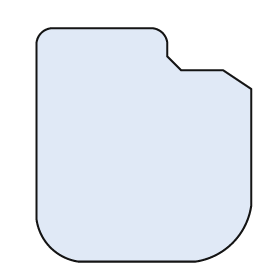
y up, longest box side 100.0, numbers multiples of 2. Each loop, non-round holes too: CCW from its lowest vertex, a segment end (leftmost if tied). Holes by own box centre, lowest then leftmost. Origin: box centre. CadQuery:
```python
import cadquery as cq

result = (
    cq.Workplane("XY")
    .moveTo(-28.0, -50.0)
    .lineTo(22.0, -50.0)
    .threePointArc((38.0, -42.0), (46.0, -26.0))
    .lineTo(46.0, 24.0)
    .lineTo(34.0, 32.0)
    .lineTo(16.0, 32.0)
    .lineTo(10.0, 38.0)
    .lineTo(10.0, 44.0)
    .threePointArc((8.0, 48.0), (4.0, 50.0))
    .lineTo(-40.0, 50.0)
    .threePointArc((-44.0, 48.0), (-46.0, 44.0))
    .lineTo(-46.0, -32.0)
    .threePointArc((-40.0, -44.0), (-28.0, -50.0))
    .close()
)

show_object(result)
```